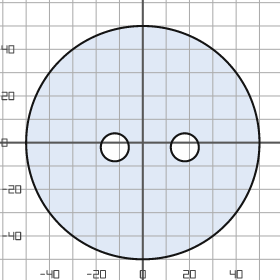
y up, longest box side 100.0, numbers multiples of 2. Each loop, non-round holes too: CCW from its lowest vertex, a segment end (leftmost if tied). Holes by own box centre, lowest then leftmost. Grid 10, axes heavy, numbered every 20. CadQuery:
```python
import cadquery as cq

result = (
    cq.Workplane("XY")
    .moveTo(0.0, 0.0)
    .circle(50.0)
    .moveTo(-12.0, -2.0)
    .circle(6.0)
    .moveTo(18.0, -2.0)
    .circle(6.0)
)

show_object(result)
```